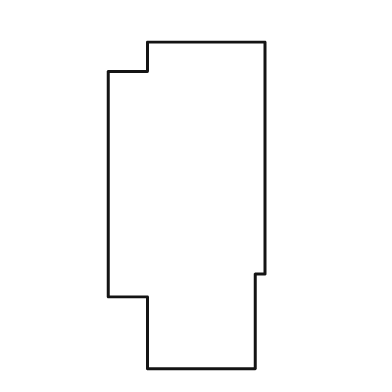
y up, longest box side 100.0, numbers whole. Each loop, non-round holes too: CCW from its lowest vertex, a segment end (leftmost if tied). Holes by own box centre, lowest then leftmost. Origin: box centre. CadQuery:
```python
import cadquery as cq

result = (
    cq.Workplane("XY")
    .moveTo(-12.0, -50.0)
    .lineTo(21.0, -50.0)
    .lineTo(21.0, -21.0)
    .lineTo(24.0, -21.0)
    .lineTo(24.0, 50.0)
    .lineTo(-12.0, 50.0)
    .lineTo(-12.0, 41.0)
    .lineTo(-24.0, 41.0)
    .lineTo(-24.0, -28.0)
    .lineTo(-12.0, -28.0)
    .close()
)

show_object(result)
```